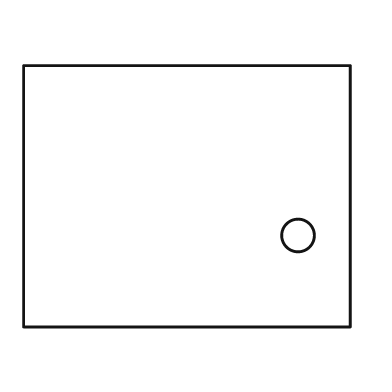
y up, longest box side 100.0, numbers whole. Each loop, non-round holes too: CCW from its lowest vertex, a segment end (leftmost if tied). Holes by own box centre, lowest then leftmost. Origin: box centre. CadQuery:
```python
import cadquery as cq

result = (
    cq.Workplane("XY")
    .moveTo(-50.0, -40.0)
    .lineTo(50.0, -40.0)
    .lineTo(50.0, 40.0)
    .lineTo(-50.0, 40.0)
    .close()
    .moveTo(34.0, -12.0)
    .circle(5.0)
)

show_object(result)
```